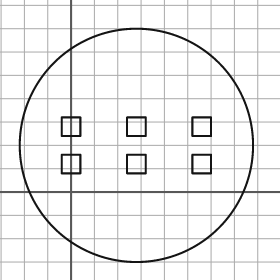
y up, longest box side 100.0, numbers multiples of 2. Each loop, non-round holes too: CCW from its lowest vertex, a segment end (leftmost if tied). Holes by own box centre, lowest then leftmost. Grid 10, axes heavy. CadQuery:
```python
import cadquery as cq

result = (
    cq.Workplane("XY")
    .moveTo(28.0, 20.0)
    .circle(50.0)
    .moveTo(-4.0, 8.0)
    .lineTo(4.0, 8.0)
    .lineTo(4.0, 16.0)
    .lineTo(-4.0, 16.0)
    .close()
    .moveTo(24.0, 8.0)
    .lineTo(32.0, 8.0)
    .lineTo(32.0, 16.0)
    .lineTo(24.0, 16.0)
    .close()
    .moveTo(52.0, 8.0)
    .lineTo(60.0, 8.0)
    .lineTo(60.0, 16.0)
    .lineTo(52.0, 16.0)
    .close()
    .moveTo(-4.0, 24.0)
    .lineTo(4.0, 24.0)
    .lineTo(4.0, 32.0)
    .lineTo(-4.0, 32.0)
    .close()
    .moveTo(24.0, 24.0)
    .lineTo(32.0, 24.0)
    .lineTo(32.0, 32.0)
    .lineTo(24.0, 32.0)
    .close()
    .moveTo(52.0, 24.0)
    .lineTo(60.0, 24.0)
    .lineTo(60.0, 32.0)
    .lineTo(52.0, 32.0)
    .close()
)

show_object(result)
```